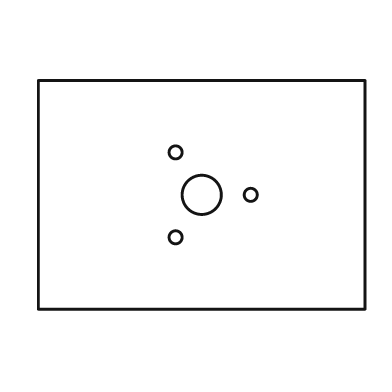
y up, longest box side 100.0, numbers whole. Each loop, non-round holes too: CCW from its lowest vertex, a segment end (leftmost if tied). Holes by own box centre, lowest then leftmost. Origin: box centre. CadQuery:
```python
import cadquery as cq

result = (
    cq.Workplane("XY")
    .moveTo(-50.0, -35.0)
    .lineTo(50.0, -35.0)
    .lineTo(50.0, 35.0)
    .lineTo(-50.0, 35.0)
    .close()
    .moveTo(-8.0, -13.0)
    .circle(2.0)
    .moveTo(0.0, 0.0)
    .circle(6.0)
    .moveTo(15.0, 0.0)
    .circle(2.0)
    .moveTo(-8.0, 13.0)
    .circle(2.0)
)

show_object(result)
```